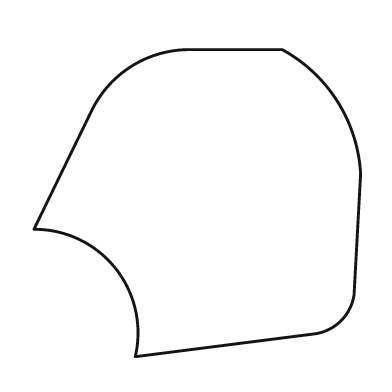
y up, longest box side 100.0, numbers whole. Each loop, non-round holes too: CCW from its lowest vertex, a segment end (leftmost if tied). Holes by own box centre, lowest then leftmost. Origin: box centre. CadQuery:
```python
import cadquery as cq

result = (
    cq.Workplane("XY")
    .moveTo(-19.0, -47.0)
    .lineTo(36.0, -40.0)
    .threePointArc((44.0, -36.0), (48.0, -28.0))
    .lineTo(50.0, 9.0)
    .threePointArc((43.0, 31.0), (26.0, 47.0))
    .lineTo(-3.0, 47.0)
    .threePointArc((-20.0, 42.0), (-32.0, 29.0))
    .lineTo(-50.0, -8.0)
    .threePointArc((-25.0, -20.0), (-19.0, -47.0))
    .close()
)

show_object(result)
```